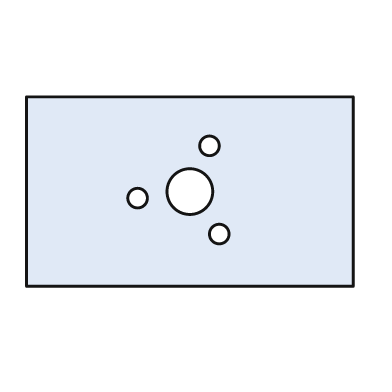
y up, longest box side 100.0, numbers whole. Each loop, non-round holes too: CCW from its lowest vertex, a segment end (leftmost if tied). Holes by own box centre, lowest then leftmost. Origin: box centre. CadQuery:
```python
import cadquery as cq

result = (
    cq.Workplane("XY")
    .moveTo(-50.0, -29.0)
    .lineTo(50.0, -29.0)
    .lineTo(50.0, 29.0)
    .lineTo(-50.0, 29.0)
    .close()
    .moveTo(9.0, -13.0)
    .circle(3.0)
    .moveTo(-16.0, -2.0)
    .circle(3.0)
    .moveTo(0.0, 0.0)
    .circle(7.0)
    .moveTo(6.0, 14.0)
    .circle(3.0)
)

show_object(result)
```